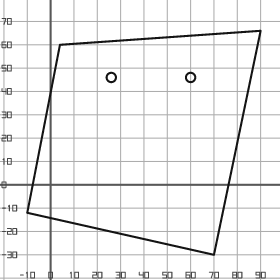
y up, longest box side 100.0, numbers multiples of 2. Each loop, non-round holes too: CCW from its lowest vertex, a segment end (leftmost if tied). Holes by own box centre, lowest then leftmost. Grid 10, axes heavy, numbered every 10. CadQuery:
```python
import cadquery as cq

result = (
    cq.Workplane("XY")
    .moveTo(70.0, -30.0)
    .lineTo(90.0, 66.0)
    .lineTo(4.0, 60.0)
    .lineTo(-10.0, -12.0)
    .close()
    .moveTo(26.0, 46.0)
    .circle(2.0)
    .moveTo(60.0, 46.0)
    .circle(2.0)
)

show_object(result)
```